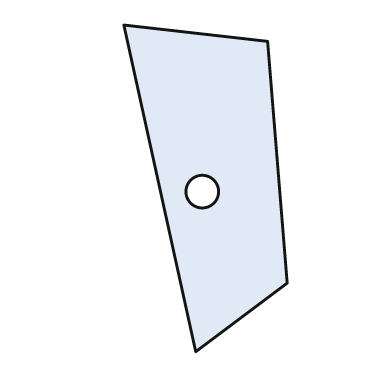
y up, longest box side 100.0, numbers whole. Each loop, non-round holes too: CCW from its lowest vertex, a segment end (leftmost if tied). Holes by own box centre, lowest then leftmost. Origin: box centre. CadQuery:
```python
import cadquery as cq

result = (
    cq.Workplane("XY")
    .moveTo(-3.0, -50.0)
    .lineTo(25.0, -29.0)
    .lineTo(19.0, 45.0)
    .lineTo(-25.0, 50.0)
    .close()
    .moveTo(-1.0, -1.0)
    .circle(5.0)
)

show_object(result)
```